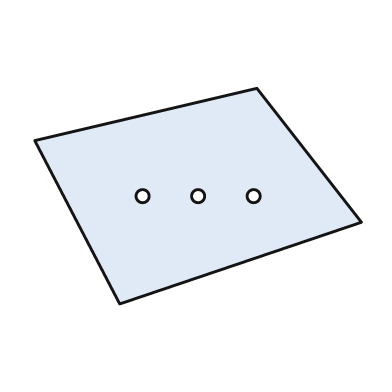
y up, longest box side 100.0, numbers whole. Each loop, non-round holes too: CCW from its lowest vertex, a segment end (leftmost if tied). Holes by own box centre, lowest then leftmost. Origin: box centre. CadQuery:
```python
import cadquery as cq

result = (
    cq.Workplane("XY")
    .moveTo(-24.0, -33.0)
    .lineTo(50.0, -8.0)
    .lineTo(18.0, 33.0)
    .lineTo(-50.0, 17.0)
    .close()
    .moveTo(-17.0, 0.0)
    .circle(2.0)
    .moveTo(0.0, 0.0)
    .circle(2.0)
    .moveTo(17.0, 0.0)
    .circle(2.0)
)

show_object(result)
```